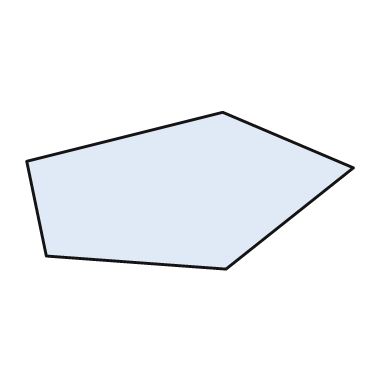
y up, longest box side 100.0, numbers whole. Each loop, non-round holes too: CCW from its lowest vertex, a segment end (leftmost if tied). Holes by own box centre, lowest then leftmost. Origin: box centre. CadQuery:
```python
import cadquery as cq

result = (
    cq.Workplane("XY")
    .moveTo(11.0, -24.0)
    .lineTo(50.0, 7.0)
    .lineTo(10.0, 24.0)
    .lineTo(-50.0, 9.0)
    .lineTo(-44.0, -20.0)
    .close()
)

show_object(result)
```